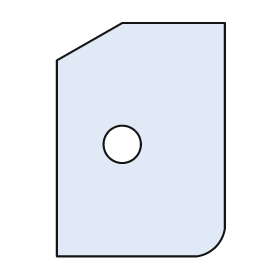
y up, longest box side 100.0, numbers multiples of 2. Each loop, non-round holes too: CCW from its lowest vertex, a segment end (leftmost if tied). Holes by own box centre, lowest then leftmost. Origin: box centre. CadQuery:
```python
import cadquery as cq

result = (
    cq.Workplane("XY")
    .moveTo(-36.0, -50.0)
    .lineTo(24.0, -50.0)
    .threePointArc((32.0, -46.0), (36.0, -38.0))
    .lineTo(36.0, 50.0)
    .lineTo(-8.0, 50.0)
    .lineTo(-36.0, 34.0)
    .close()
    .moveTo(-8.0, -2.0)
    .circle(8.0)
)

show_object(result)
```